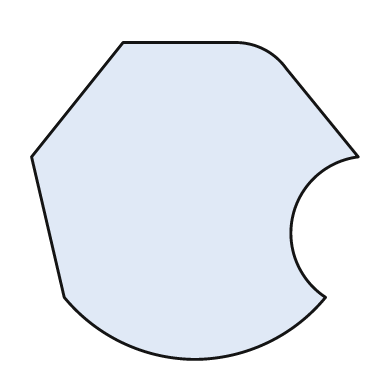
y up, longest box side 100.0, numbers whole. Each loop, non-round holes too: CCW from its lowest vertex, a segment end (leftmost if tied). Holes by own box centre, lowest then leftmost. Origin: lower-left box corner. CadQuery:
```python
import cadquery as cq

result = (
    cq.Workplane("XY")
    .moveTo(50.0, 0.0)
    .threePointArc((72.0, 5.0), (90.0, 19.0))
    .threePointArc((80.0, 44.0), (100.0, 62.0))
    .lineTo(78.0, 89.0)
    .threePointArc((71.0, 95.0), (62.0, 97.0))
    .lineTo(28.0, 97.0)
    .lineTo(0.0, 62.0)
    .lineTo(10.0, 19.0)
    .threePointArc((28.0, 5.0), (50.0, 0.0))
    .close()
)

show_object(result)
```